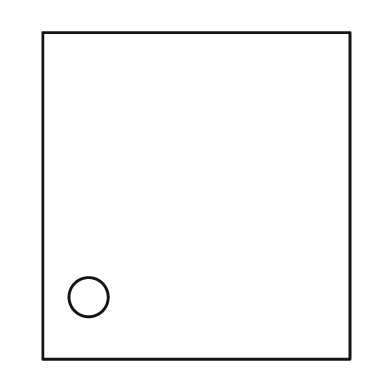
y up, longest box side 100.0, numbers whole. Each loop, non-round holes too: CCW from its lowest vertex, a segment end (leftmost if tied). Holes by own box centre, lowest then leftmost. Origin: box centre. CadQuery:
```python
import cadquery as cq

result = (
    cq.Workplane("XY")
    .moveTo(-47.0, -50.0)
    .lineTo(47.0, -50.0)
    .lineTo(47.0, 50.0)
    .lineTo(-47.0, 50.0)
    .close()
    .moveTo(-33.0, -31.0)
    .circle(6.0)
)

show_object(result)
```